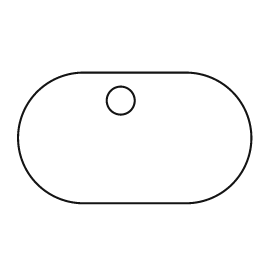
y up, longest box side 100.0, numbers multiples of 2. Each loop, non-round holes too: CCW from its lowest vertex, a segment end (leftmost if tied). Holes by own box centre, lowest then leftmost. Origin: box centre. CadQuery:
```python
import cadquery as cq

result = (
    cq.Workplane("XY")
    .moveTo(-22.0, -28.0)
    .lineTo(22.0, -28.0)
    .threePointArc((50.0, 0.0), (22.0, 28.0))
    .lineTo(-22.0, 28.0)
    .threePointArc((-50.0, 0.0), (-22.0, -28.0))
    .close()
    .moveTo(-6.0, 16.0)
    .circle(6.0)
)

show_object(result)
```